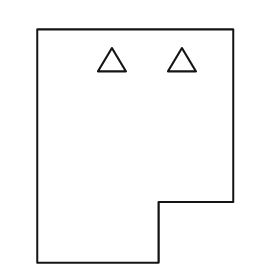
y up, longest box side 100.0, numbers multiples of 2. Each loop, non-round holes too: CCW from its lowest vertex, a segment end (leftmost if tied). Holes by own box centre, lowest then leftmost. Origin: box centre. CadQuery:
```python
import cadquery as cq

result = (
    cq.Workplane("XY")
    .moveTo(-42.0, -50.0)
    .lineTo(10.0, -50.0)
    .lineTo(10.0, -24.0)
    .lineTo(42.0, -24.0)
    .lineTo(42.0, 50.0)
    .lineTo(-42.0, 50.0)
    .close()
    .moveTo(-16.0, 32.0)
    .lineTo(-4.0, 32.0)
    .lineTo(-10.0, 42.0)
    .close()
    .moveTo(14.0, 32.0)
    .lineTo(26.0, 32.0)
    .lineTo(20.0, 42.0)
    .close()
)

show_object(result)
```